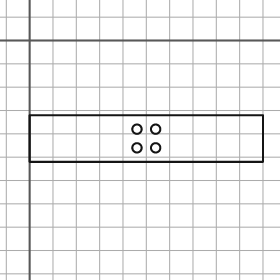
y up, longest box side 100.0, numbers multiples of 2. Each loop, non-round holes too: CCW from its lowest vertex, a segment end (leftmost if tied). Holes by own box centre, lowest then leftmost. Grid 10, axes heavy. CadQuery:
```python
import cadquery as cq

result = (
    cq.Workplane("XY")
    .moveTo(0.0, -52.0)
    .lineTo(100.0, -52.0)
    .lineTo(100.0, -32.0)
    .lineTo(0.0, -32.0)
    .close()
    .moveTo(46.0, -46.0)
    .circle(2.0)
    .moveTo(54.0, -46.0)
    .circle(2.0)
    .moveTo(46.0, -38.0)
    .circle(2.0)
    .moveTo(54.0, -38.0)
    .circle(2.0)
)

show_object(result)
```